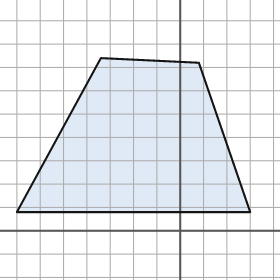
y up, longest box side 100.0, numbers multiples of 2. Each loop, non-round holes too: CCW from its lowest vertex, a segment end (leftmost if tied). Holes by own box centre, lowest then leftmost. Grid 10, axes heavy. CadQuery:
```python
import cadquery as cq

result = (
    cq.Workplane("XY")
    .moveTo(-70.0, 8.0)
    .lineTo(30.0, 8.0)
    .lineTo(8.0, 72.0)
    .lineTo(-34.0, 74.0)
    .close()
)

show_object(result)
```